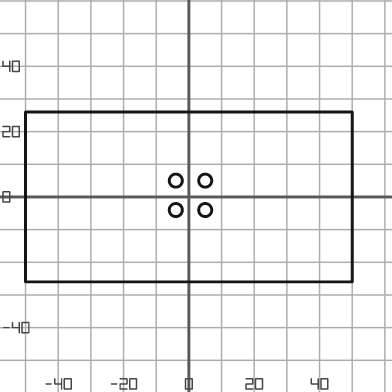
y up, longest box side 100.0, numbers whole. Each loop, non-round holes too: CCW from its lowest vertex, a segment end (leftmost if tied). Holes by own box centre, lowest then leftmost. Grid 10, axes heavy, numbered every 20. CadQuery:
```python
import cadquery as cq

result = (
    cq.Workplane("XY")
    .moveTo(-50.0, -26.0)
    .lineTo(50.0, -26.0)
    .lineTo(50.0, 26.0)
    .lineTo(-50.0, 26.0)
    .close()
    .moveTo(-4.0, -4.0)
    .circle(2.0)
    .moveTo(5.0, -4.0)
    .circle(2.0)
    .moveTo(-4.0, 5.0)
    .circle(2.0)
    .moveTo(5.0, 5.0)
    .circle(2.0)
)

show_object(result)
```